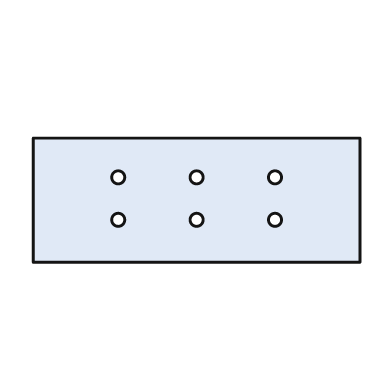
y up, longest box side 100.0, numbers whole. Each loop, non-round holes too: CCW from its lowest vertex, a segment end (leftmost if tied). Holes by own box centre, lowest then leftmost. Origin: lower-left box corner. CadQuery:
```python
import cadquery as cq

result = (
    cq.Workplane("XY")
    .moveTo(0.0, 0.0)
    .lineTo(100.0, 0.0)
    .lineTo(100.0, 38.0)
    .lineTo(0.0, 38.0)
    .close()
    .moveTo(26.0, 13.0)
    .circle(2.0)
    .moveTo(50.0, 13.0)
    .circle(2.0)
    .moveTo(74.0, 13.0)
    .circle(2.0)
    .moveTo(26.0, 26.0)
    .circle(2.0)
    .moveTo(50.0, 26.0)
    .circle(2.0)
    .moveTo(74.0, 26.0)
    .circle(2.0)
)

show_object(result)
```